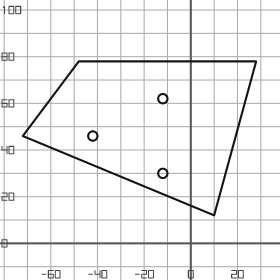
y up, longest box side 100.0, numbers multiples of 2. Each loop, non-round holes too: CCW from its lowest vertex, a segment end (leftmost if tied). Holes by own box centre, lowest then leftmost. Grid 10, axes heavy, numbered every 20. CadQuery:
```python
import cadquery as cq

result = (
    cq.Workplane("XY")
    .moveTo(10.0, 12.0)
    .lineTo(28.0, 78.0)
    .lineTo(-48.0, 78.0)
    .lineTo(-72.0, 46.0)
    .close()
    .moveTo(-12.0, 30.0)
    .circle(2.0)
    .moveTo(-42.0, 46.0)
    .circle(2.0)
    .moveTo(-12.0, 62.0)
    .circle(2.0)
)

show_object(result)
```